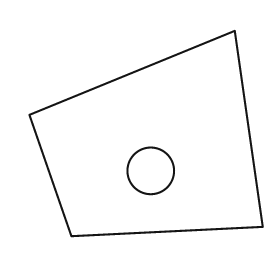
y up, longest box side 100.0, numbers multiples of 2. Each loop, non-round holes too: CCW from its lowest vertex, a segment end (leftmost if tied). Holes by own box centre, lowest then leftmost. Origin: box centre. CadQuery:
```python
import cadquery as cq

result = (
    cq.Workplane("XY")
    .moveTo(-32.0, -44.0)
    .lineTo(50.0, -40.0)
    .lineTo(38.0, 44.0)
    .lineTo(-50.0, 8.0)
    .close()
    .moveTo(2.0, -16.0)
    .circle(10.0)
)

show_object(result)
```